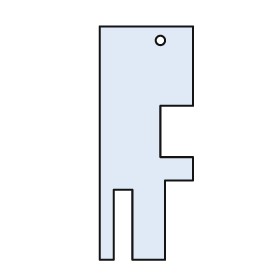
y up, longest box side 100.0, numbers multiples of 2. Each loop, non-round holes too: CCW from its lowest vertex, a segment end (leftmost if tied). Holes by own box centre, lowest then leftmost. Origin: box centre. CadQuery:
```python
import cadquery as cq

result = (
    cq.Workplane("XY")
    .moveTo(-20.0, -50.0)
    .lineTo(-14.0, -50.0)
    .lineTo(-14.0, -20.0)
    .lineTo(-6.0, -20.0)
    .lineTo(-6.0, -50.0)
    .lineTo(8.0, -50.0)
    .lineTo(8.0, -16.0)
    .lineTo(20.0, -16.0)
    .lineTo(20.0, -6.0)
    .lineTo(6.0, -6.0)
    .lineTo(6.0, 16.0)
    .lineTo(20.0, 16.0)
    .lineTo(20.0, 50.0)
    .lineTo(-20.0, 50.0)
    .close()
    .moveTo(6.0, 44.0)
    .circle(2.0)
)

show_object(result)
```